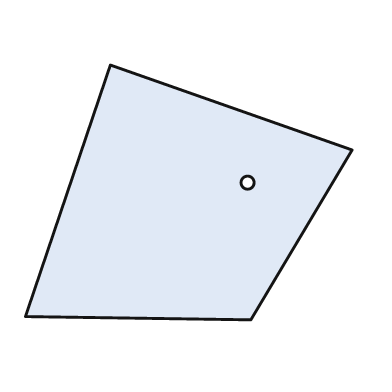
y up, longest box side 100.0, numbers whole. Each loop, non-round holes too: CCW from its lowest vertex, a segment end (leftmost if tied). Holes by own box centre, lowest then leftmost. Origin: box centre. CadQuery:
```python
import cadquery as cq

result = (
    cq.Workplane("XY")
    .moveTo(19.0, -39.0)
    .lineTo(50.0, 13.0)
    .lineTo(-24.0, 39.0)
    .lineTo(-50.0, -38.0)
    .close()
    .moveTo(18.0, 3.0)
    .circle(2.0)
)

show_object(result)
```